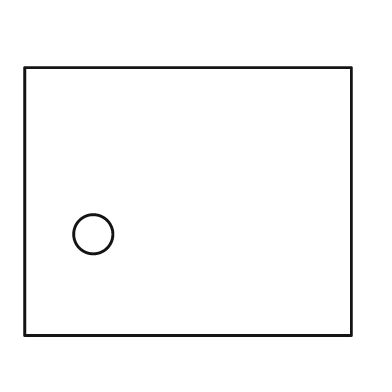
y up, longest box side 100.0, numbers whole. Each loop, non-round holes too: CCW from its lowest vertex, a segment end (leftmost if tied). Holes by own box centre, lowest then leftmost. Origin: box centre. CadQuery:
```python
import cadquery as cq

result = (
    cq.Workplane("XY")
    .moveTo(-50.0, -41.0)
    .lineTo(50.0, -41.0)
    .lineTo(50.0, 41.0)
    .lineTo(-50.0, 41.0)
    .close()
    .moveTo(-29.0, -10.0)
    .circle(6.0)
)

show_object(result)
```